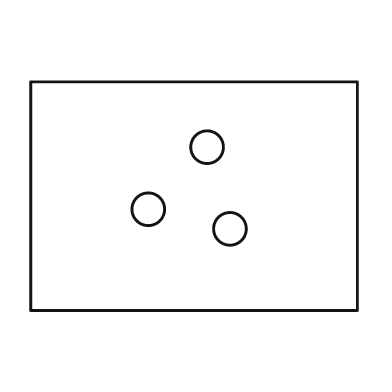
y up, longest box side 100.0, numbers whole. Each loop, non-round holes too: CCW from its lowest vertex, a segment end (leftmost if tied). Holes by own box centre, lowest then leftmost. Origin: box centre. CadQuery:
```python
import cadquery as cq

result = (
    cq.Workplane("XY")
    .moveTo(-50.0, -35.0)
    .lineTo(50.0, -35.0)
    .lineTo(50.0, 35.0)
    .lineTo(-50.0, 35.0)
    .close()
    .moveTo(11.0, -10.0)
    .circle(5.0)
    .moveTo(-14.0, -4.0)
    .circle(5.0)
    .moveTo(4.0, 15.0)
    .circle(5.0)
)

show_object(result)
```